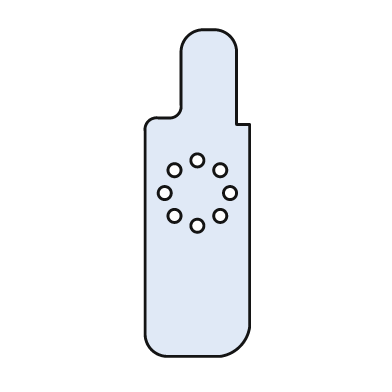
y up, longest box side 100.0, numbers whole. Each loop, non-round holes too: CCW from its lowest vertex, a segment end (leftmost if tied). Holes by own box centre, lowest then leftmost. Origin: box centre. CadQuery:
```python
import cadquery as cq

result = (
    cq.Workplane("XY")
    .moveTo(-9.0, -50.0)
    .lineTo(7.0, -50.0)
    .threePointArc((13.0, -47.0), (16.0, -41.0))
    .lineTo(16.0, 21.0)
    .lineTo(12.0, 21.0)
    .lineTo(12.0, 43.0)
    .threePointArc((10.0, 48.0), (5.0, 50.0))
    .lineTo(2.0, 50.0)
    .threePointArc((-3.0, 48.0), (-5.0, 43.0))
    .lineTo(-5.0, 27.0)
    .threePointArc((-6.0, 24.0), (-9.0, 23.0))
    .lineTo(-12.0, 23.0)
    .threePointArc((-15.0, 22.0), (-16.0, 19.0))
    .lineTo(-16.0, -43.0)
    .threePointArc((-14.0, -48.0), (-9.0, -50.0))
    .close()
    .moveTo(0.0, -10.0)
    .circle(2.0)
    .moveTo(-7.0, -7.0)
    .circle(2.0)
    .moveTo(7.0, -7.0)
    .circle(2.0)
    .moveTo(-10.0, 0.0)
    .circle(2.0)
    .moveTo(10.0, 0.0)
    .circle(2.0)
    .moveTo(-7.0, 7.0)
    .circle(2.0)
    .moveTo(7.0, 7.0)
    .circle(2.0)
    .moveTo(0.0, 10.0)
    .circle(2.0)
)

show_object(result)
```